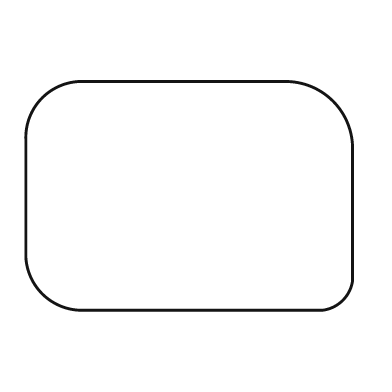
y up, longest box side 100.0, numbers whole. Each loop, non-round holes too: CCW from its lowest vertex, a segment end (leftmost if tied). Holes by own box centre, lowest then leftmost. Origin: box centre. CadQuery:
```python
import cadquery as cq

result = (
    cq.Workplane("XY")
    .moveTo(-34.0, -35.0)
    .lineTo(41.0, -35.0)
    .threePointArc((47.0, -32.0), (50.0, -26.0))
    .lineTo(50.0, 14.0)
    .threePointArc((44.0, 29.0), (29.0, 35.0))
    .lineTo(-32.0, 35.0)
    .threePointArc((-45.0, 30.0), (-50.0, 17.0))
    .lineTo(-50.0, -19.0)
    .threePointArc((-45.0, -30.0), (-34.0, -35.0))
    .close()
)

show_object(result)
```